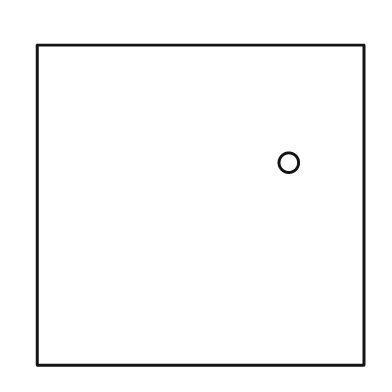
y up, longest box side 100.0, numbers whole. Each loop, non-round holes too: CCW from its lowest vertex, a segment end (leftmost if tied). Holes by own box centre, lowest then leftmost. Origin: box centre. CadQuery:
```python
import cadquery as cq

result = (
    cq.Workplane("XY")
    .moveTo(-50.0, -49.0)
    .lineTo(50.0, -49.0)
    .lineTo(50.0, 49.0)
    .lineTo(-50.0, 49.0)
    .close()
    .moveTo(27.0, 13.0)
    .circle(3.0)
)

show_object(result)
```